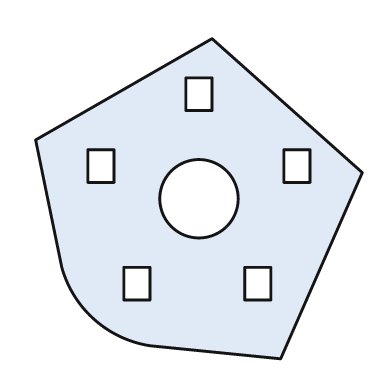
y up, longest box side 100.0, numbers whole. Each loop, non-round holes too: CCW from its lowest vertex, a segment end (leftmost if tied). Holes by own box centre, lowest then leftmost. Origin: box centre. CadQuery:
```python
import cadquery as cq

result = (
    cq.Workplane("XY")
    .moveTo(25.0, -49.0)
    .lineTo(50.0, 8.0)
    .lineTo(4.0, 49.0)
    .lineTo(-50.0, 18.0)
    .lineTo(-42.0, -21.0)
    .threePointArc((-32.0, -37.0), (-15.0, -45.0))
    .close()
    .moveTo(-23.0, -31.0)
    .lineTo(-15.0, -31.0)
    .lineTo(-15.0, -21.0)
    .lineTo(-23.0, -21.0)
    .close()
    .moveTo(14.0, -31.0)
    .lineTo(22.0, -31.0)
    .lineTo(22.0, -21.0)
    .lineTo(14.0, -21.0)
    .close()
    .moveTo(0.0, 0.0)
    .circle(12.0)
    .moveTo(-34.0, 5.0)
    .lineTo(-26.0, 5.0)
    .lineTo(-26.0, 15.0)
    .lineTo(-34.0, 15.0)
    .close()
    .moveTo(26.0, 5.0)
    .lineTo(34.0, 5.0)
    .lineTo(34.0, 15.0)
    .lineTo(26.0, 15.0)
    .close()
    .moveTo(-4.0, 27.0)
    .lineTo(4.0, 27.0)
    .lineTo(4.0, 37.0)
    .lineTo(-4.0, 37.0)
    .close()
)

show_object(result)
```